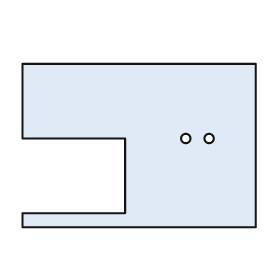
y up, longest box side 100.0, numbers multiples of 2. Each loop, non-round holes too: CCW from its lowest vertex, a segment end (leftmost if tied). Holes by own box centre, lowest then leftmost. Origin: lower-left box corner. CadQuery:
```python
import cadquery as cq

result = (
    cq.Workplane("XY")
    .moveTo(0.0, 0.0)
    .lineTo(100.0, 0.0)
    .lineTo(100.0, 70.0)
    .lineTo(0.0, 70.0)
    .lineTo(0.0, 38.0)
    .lineTo(44.0, 38.0)
    .lineTo(44.0, 6.0)
    .lineTo(0.0, 6.0)
    .close()
    .moveTo(70.0, 38.0)
    .circle(2.0)
    .moveTo(80.0, 38.0)
    .circle(2.0)
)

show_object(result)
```